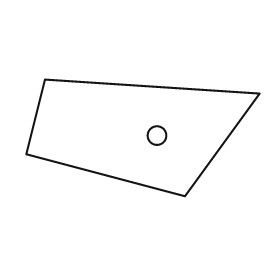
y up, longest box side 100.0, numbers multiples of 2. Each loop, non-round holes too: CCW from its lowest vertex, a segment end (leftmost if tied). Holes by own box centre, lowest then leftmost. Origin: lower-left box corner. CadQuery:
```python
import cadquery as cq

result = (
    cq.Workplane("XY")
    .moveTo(68.0, 0.0)
    .lineTo(100.0, 44.0)
    .lineTo(8.0, 50.0)
    .lineTo(0.0, 18.0)
    .close()
    .moveTo(56.0, 26.0)
    .circle(4.0)
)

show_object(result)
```